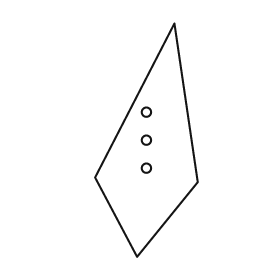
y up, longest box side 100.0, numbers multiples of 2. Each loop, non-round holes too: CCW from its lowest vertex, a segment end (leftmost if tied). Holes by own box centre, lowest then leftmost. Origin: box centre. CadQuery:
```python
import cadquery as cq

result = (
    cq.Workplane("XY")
    .moveTo(-4.0, -50.0)
    .lineTo(22.0, -18.0)
    .lineTo(12.0, 50.0)
    .lineTo(-22.0, -16.0)
    .close()
    .moveTo(0.0, -12.0)
    .circle(2.0)
    .moveTo(0.0, 0.0)
    .circle(2.0)
    .moveTo(0.0, 12.0)
    .circle(2.0)
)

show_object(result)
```